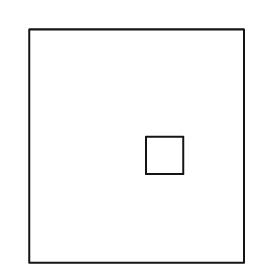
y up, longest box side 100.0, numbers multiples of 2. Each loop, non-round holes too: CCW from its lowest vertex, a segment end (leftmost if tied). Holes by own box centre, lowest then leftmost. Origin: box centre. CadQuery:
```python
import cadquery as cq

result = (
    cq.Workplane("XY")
    .moveTo(-46.0, -50.0)
    .lineTo(46.0, -50.0)
    .lineTo(46.0, 50.0)
    .lineTo(-46.0, 50.0)
    .close()
    .moveTo(4.0, -12.0)
    .lineTo(20.0, -12.0)
    .lineTo(20.0, 4.0)
    .lineTo(4.0, 4.0)
    .close()
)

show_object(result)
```